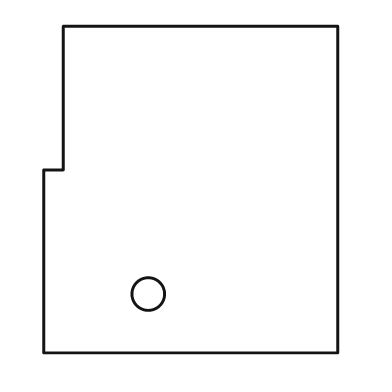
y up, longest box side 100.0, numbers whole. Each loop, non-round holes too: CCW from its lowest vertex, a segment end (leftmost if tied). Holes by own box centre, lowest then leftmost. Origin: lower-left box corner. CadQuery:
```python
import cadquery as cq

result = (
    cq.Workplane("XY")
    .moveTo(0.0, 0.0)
    .lineTo(90.0, 0.0)
    .lineTo(90.0, 100.0)
    .lineTo(6.0, 100.0)
    .lineTo(6.0, 56.0)
    .lineTo(0.0, 56.0)
    .close()
    .moveTo(32.0, 18.0)
    .circle(5.0)
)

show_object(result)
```